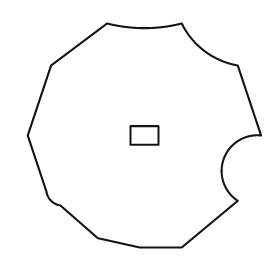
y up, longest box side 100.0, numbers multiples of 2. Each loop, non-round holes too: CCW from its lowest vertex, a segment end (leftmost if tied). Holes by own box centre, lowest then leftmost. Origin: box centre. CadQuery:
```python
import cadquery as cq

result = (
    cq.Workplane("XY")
    .moveTo(-2.0, -48.0)
    .lineTo(16.0, -48.0)
    .lineTo(40.0, -28.0)
    .threePointArc((34.0, -10.0), (50.0, 0.0))
    .lineTo(40.0, 30.0)
    .threePointArc((26.0, 36.0), (16.0, 48.0))
    .threePointArc((0.0, 46.0), (-16.0, 48.0))
    .lineTo(-40.0, 30.0)
    .lineTo(-50.0, 0.0)
    .lineTo(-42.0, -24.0)
    .threePointArc((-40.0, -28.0), (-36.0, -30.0))
    .lineTo(-20.0, -44.0)
    .close()
    .moveTo(-6.0, -4.0)
    .lineTo(6.0, -4.0)
    .lineTo(6.0, 4.0)
    .lineTo(-6.0, 4.0)
    .close()
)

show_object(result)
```